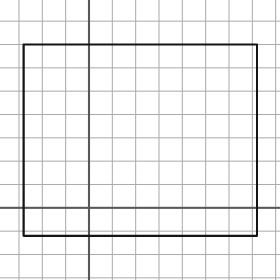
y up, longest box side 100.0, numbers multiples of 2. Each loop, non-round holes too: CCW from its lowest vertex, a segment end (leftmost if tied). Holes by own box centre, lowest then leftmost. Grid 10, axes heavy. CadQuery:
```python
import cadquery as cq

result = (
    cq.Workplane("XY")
    .moveTo(-28.0, -12.0)
    .lineTo(72.0, -12.0)
    .lineTo(72.0, 70.0)
    .lineTo(-28.0, 70.0)
    .close()
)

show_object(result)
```